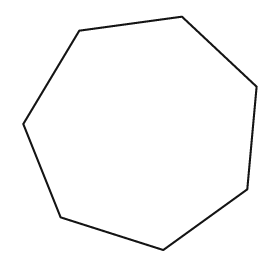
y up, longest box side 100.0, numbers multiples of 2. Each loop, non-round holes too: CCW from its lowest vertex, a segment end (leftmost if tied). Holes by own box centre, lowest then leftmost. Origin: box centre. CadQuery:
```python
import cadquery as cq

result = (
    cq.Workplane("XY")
    .moveTo(10.0, -50.0)
    .lineTo(46.0, -24.0)
    .lineTo(50.0, 20.0)
    .lineTo(18.0, 50.0)
    .lineTo(-26.0, 44.0)
    .lineTo(-50.0, 4.0)
    .lineTo(-34.0, -36.0)
    .close()
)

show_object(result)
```